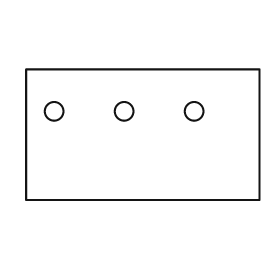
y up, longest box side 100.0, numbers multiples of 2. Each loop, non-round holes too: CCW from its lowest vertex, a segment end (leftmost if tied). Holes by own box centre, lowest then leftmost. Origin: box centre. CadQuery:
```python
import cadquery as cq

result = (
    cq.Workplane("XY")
    .moveTo(-50.0, -28.0)
    .lineTo(50.0, -28.0)
    .lineTo(50.0, 28.0)
    .lineTo(-50.0, 28.0)
    .close()
    .moveTo(-38.0, 10.0)
    .circle(4.0)
    .moveTo(-8.0, 10.0)
    .circle(4.0)
    .moveTo(22.0, 10.0)
    .circle(4.0)
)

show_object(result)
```